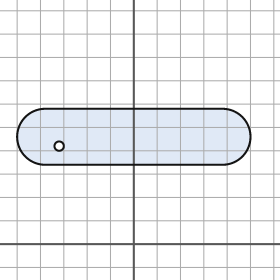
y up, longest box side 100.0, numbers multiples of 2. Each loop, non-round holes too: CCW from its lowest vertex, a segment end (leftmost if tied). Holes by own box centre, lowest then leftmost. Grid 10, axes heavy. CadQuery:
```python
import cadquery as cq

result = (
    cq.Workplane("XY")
    .moveTo(-38.0, 34.0)
    .lineTo(38.0, 34.0)
    .threePointArc((50.0, 46.0), (38.0, 58.0))
    .lineTo(-38.0, 58.0)
    .threePointArc((-50.0, 46.0), (-38.0, 34.0))
    .close()
    .moveTo(-32.0, 42.0)
    .circle(2.0)
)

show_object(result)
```